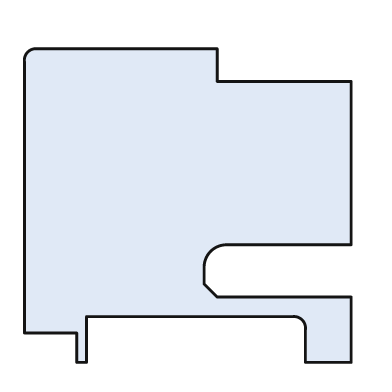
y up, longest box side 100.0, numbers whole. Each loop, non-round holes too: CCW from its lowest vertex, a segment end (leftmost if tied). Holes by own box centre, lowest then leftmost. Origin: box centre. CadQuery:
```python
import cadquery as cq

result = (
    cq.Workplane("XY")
    .moveTo(-34.0, -48.0)
    .lineTo(-31.0, -48.0)
    .lineTo(-31.0, -34.0)
    .lineTo(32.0, -34.0)
    .threePointArc((35.0, -35.0), (36.0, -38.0))
    .lineTo(36.0, -48.0)
    .lineTo(50.0, -48.0)
    .lineTo(50.0, -28.0)
    .lineTo(9.0, -28.0)
    .lineTo(5.0, -24.0)
    .lineTo(5.0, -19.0)
    .threePointArc((7.0, -14.0), (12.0, -12.0))
    .lineTo(50.0, -12.0)
    .lineTo(50.0, 38.0)
    .lineTo(9.0, 38.0)
    .lineTo(9.0, 48.0)
    .lineTo(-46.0, 48.0)
    .threePointArc((-49.0, 47.0), (-50.0, 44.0))
    .lineTo(-50.0, -39.0)
    .lineTo(-34.0, -39.0)
    .close()
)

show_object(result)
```